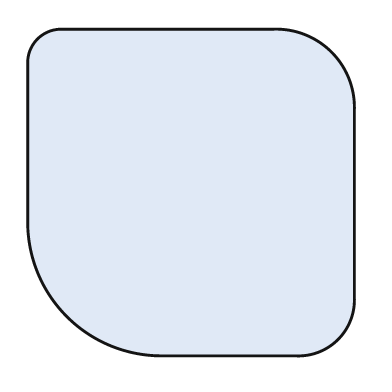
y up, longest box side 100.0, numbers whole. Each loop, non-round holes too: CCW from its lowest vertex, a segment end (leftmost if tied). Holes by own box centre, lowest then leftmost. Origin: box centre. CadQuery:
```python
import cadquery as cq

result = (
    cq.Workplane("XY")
    .moveTo(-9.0, -50.0)
    .lineTo(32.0, -50.0)
    .threePointArc((45.0, -45.0), (50.0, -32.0))
    .lineTo(50.0, 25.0)
    .threePointArc((43.0, 43.0), (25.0, 50.0))
    .lineTo(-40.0, 50.0)
    .threePointArc((-47.0, 47.0), (-50.0, 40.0))
    .lineTo(-50.0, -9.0)
    .threePointArc((-38.0, -38.0), (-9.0, -50.0))
    .close()
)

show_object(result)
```